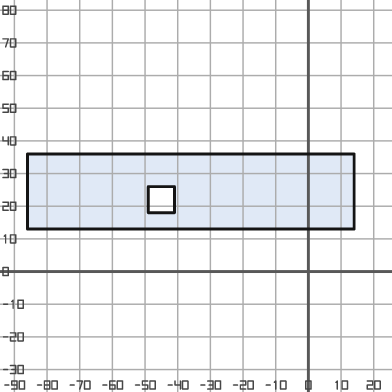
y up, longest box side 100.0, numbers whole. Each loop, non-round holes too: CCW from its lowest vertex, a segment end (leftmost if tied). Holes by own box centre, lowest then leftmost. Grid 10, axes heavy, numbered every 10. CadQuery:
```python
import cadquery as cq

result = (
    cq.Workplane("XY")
    .moveTo(-86.0, 13.0)
    .lineTo(14.0, 13.0)
    .lineTo(14.0, 36.0)
    .lineTo(-86.0, 36.0)
    .close()
    .moveTo(-49.0, 18.0)
    .lineTo(-41.0, 18.0)
    .lineTo(-41.0, 26.0)
    .lineTo(-49.0, 26.0)
    .close()
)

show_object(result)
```